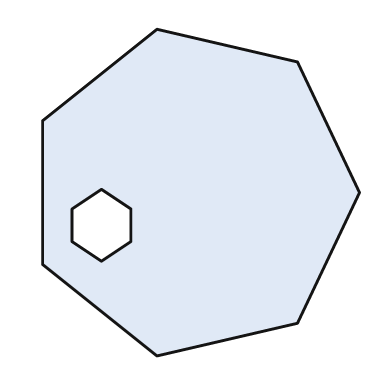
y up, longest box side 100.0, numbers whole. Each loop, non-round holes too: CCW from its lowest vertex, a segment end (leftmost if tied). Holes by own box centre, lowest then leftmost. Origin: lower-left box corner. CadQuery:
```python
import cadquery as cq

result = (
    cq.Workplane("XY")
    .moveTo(35.0, 0.0)
    .lineTo(78.0, 10.0)
    .lineTo(97.0, 50.0)
    .lineTo(78.0, 90.0)
    .lineTo(35.0, 100.0)
    .lineTo(0.0, 72.0)
    .lineTo(0.0, 28.0)
    .close()
    .moveTo(18.0, 29.0)
    .lineTo(27.0, 35.0)
    .lineTo(27.0, 45.0)
    .lineTo(18.0, 51.0)
    .lineTo(9.0, 45.0)
    .lineTo(9.0, 35.0)
    .close()
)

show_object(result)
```